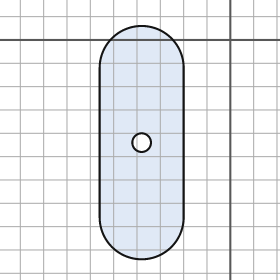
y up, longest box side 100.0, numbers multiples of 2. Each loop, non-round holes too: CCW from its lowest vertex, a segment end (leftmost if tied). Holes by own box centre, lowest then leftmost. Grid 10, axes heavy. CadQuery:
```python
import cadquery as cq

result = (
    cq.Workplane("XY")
    .moveTo(-56.0, -76.0)
    .threePointArc((-38.0, -94.0), (-20.0, -76.0))
    .lineTo(-20.0, -12.0)
    .threePointArc((-38.0, 6.0), (-56.0, -12.0))
    .close()
    .moveTo(-38.0, -44.0)
    .circle(4.0)
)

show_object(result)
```